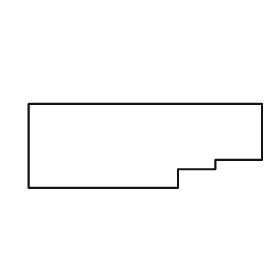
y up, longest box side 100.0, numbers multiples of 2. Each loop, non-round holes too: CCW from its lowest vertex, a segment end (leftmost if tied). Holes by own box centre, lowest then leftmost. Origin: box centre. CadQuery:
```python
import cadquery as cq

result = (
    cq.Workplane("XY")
    .moveTo(-50.0, -18.0)
    .lineTo(14.0, -18.0)
    .lineTo(14.0, -10.0)
    .lineTo(30.0, -10.0)
    .lineTo(30.0, -6.0)
    .lineTo(50.0, -6.0)
    .lineTo(50.0, 18.0)
    .lineTo(-50.0, 18.0)
    .close()
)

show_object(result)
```